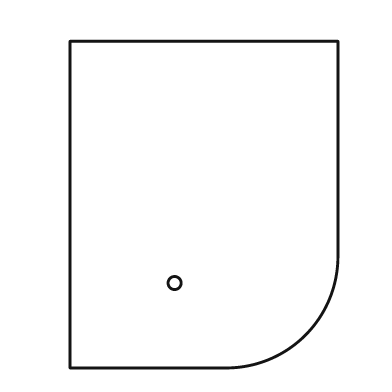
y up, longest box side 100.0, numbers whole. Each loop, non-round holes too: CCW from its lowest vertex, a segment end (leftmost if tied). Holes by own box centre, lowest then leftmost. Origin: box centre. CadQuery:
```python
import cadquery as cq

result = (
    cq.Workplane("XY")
    .moveTo(-41.0, -50.0)
    .lineTo(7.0, -50.0)
    .threePointArc((31.0, -40.0), (41.0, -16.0))
    .lineTo(41.0, 50.0)
    .lineTo(-41.0, 50.0)
    .close()
    .moveTo(-9.0, -24.0)
    .circle(2.0)
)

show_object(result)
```